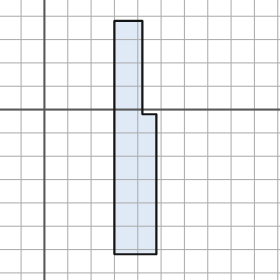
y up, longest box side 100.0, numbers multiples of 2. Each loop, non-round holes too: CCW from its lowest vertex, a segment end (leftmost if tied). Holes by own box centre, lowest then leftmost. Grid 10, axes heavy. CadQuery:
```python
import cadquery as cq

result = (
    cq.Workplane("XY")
    .moveTo(30.0, -62.0)
    .lineTo(48.0, -62.0)
    .lineTo(48.0, -2.0)
    .lineTo(42.0, -2.0)
    .lineTo(42.0, 38.0)
    .lineTo(30.0, 38.0)
    .close()
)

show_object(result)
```